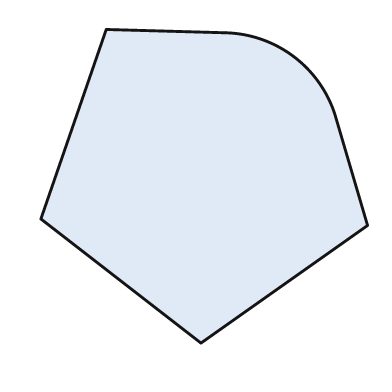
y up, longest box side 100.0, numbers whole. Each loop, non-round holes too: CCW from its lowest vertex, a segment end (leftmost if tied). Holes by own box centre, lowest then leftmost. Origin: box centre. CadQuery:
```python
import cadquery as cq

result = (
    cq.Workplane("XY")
    .moveTo(-1.0, -48.0)
    .lineTo(50.0, -12.0)
    .lineTo(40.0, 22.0)
    .threePointArc((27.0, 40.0), (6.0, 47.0))
    .lineTo(-30.0, 48.0)
    .lineTo(-50.0, -10.0)
    .close()
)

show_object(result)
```